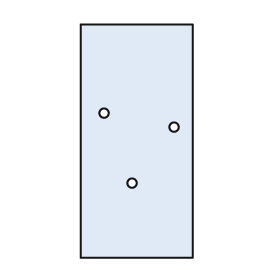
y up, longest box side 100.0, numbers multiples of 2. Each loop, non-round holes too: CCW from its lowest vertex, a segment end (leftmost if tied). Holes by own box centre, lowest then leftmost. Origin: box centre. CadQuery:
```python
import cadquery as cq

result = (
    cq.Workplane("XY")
    .moveTo(-24.0, -50.0)
    .lineTo(24.0, -50.0)
    .lineTo(24.0, 50.0)
    .lineTo(-24.0, 50.0)
    .close()
    .moveTo(-2.0, -18.0)
    .circle(2.0)
    .moveTo(16.0, 6.0)
    .circle(2.0)
    .moveTo(-14.0, 12.0)
    .circle(2.0)
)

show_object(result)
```